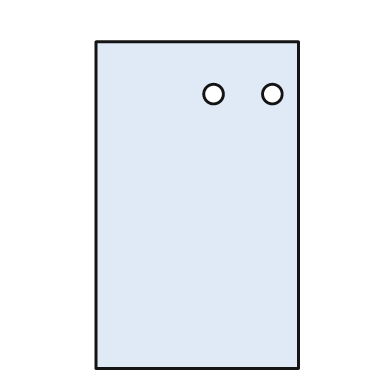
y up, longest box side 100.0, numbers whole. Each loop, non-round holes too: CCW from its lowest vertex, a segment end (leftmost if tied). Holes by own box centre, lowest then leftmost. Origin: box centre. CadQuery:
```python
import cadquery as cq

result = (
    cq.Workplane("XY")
    .moveTo(-31.0, -50.0)
    .lineTo(31.0, -50.0)
    .lineTo(31.0, 50.0)
    .lineTo(-31.0, 50.0)
    .close()
    .moveTo(5.0, 34.0)
    .circle(3.0)
    .moveTo(23.0, 34.0)
    .circle(3.0)
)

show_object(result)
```